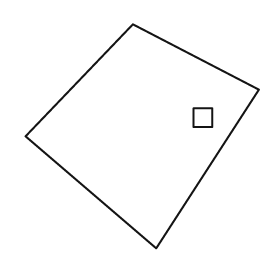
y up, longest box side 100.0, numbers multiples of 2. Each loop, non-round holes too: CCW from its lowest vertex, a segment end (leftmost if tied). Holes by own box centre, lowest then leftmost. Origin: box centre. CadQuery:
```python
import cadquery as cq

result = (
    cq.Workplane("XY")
    .moveTo(6.0, -48.0)
    .lineTo(50.0, 20.0)
    .lineTo(-4.0, 48.0)
    .lineTo(-50.0, 0.0)
    .close()
    .moveTo(22.0, 4.0)
    .lineTo(30.0, 4.0)
    .lineTo(30.0, 12.0)
    .lineTo(22.0, 12.0)
    .close()
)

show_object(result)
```